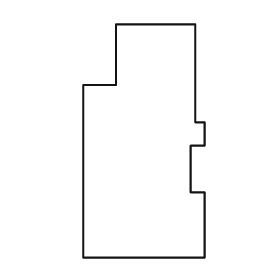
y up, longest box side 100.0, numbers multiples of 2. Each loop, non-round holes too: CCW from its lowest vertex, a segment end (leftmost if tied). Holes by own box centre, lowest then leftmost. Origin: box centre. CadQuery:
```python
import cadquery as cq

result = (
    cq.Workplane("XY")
    .moveTo(-26.0, -50.0)
    .lineTo(26.0, -50.0)
    .lineTo(26.0, -22.0)
    .lineTo(20.0, -22.0)
    .lineTo(20.0, -2.0)
    .lineTo(26.0, -2.0)
    .lineTo(26.0, 8.0)
    .lineTo(22.0, 8.0)
    .lineTo(22.0, 50.0)
    .lineTo(-12.0, 50.0)
    .lineTo(-12.0, 24.0)
    .lineTo(-26.0, 24.0)
    .close()
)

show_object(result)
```